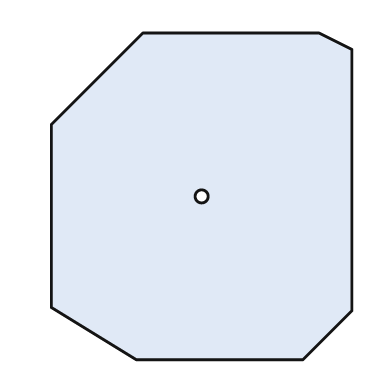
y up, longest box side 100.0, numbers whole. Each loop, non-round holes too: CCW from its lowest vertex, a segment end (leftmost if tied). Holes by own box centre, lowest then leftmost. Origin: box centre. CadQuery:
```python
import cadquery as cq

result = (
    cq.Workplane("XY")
    .moveTo(-20.0, -50.0)
    .lineTo(31.0, -50.0)
    .lineTo(46.0, -35.0)
    .lineTo(46.0, 45.0)
    .lineTo(36.0, 50.0)
    .lineTo(-18.0, 50.0)
    .lineTo(-46.0, 22.0)
    .lineTo(-46.0, -34.0)
    .close()
    .moveTo(0.0, 0.0)
    .circle(2.0)
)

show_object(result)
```